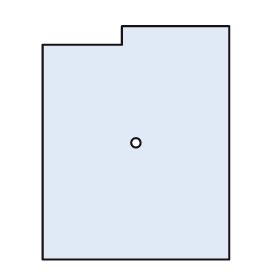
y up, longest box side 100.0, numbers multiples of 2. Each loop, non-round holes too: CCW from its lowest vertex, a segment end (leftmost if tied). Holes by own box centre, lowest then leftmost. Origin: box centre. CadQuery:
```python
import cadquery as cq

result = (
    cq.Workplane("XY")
    .moveTo(-40.0, -50.0)
    .lineTo(40.0, -50.0)
    .lineTo(40.0, 50.0)
    .lineTo(-6.0, 50.0)
    .lineTo(-6.0, 42.0)
    .lineTo(-40.0, 42.0)
    .close()
    .moveTo(0.0, 0.0)
    .circle(2.0)
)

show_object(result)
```